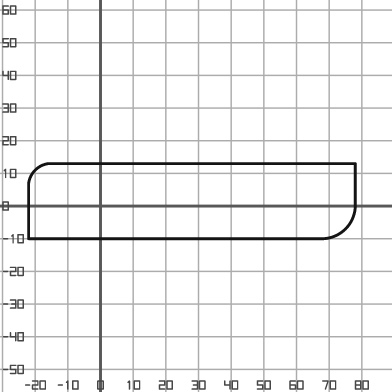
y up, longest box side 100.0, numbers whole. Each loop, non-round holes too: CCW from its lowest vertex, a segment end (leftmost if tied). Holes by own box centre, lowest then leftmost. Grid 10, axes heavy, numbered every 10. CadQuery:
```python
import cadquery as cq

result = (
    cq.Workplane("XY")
    .moveTo(-22.0, -10.0)
    .lineTo(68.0, -10.0)
    .threePointArc((75.0, -7.0), (78.0, 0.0))
    .lineTo(78.0, 13.0)
    .lineTo(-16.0, 13.0)
    .threePointArc((-20.0, 11.0), (-22.0, 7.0))
    .close()
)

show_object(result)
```